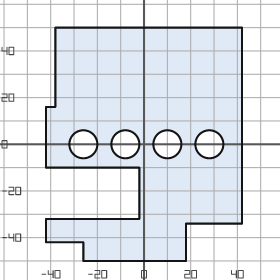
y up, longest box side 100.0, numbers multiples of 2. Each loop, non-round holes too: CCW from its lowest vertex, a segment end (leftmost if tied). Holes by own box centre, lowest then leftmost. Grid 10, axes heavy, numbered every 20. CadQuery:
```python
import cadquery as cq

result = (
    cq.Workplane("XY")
    .moveTo(-26.0, -50.0)
    .lineTo(18.0, -50.0)
    .lineTo(18.0, -34.0)
    .lineTo(42.0, -34.0)
    .lineTo(42.0, 50.0)
    .lineTo(-38.0, 50.0)
    .lineTo(-38.0, 16.0)
    .lineTo(-42.0, 16.0)
    .lineTo(-42.0, -10.0)
    .lineTo(-2.0, -10.0)
    .lineTo(-2.0, -32.0)
    .lineTo(-42.0, -32.0)
    .lineTo(-42.0, -42.0)
    .lineTo(-26.0, -42.0)
    .close()
    .moveTo(-26.0, 0.0)
    .circle(6.0)
    .moveTo(-8.0, 0.0)
    .circle(6.0)
    .moveTo(10.0, 0.0)
    .circle(6.0)
    .moveTo(28.0, 0.0)
    .circle(6.0)
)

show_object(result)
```